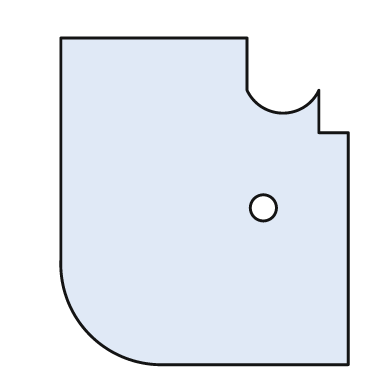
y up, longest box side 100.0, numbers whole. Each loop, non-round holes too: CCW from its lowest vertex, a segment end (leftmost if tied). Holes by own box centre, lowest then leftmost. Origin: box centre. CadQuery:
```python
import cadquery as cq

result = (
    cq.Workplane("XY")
    .moveTo(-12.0, -50.0)
    .lineTo(44.0, -50.0)
    .lineTo(44.0, 21.0)
    .lineTo(35.0, 21.0)
    .lineTo(35.0, 34.0)
    .threePointArc((24.0, 27.0), (13.0, 34.0))
    .lineTo(13.0, 50.0)
    .lineTo(-44.0, 50.0)
    .lineTo(-44.0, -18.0)
    .threePointArc((-35.0, -41.0), (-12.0, -50.0))
    .close()
    .moveTo(18.0, -2.0)
    .circle(4.0)
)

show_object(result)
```